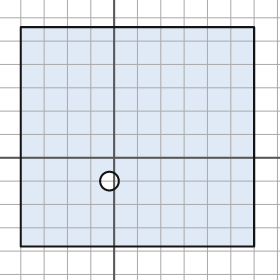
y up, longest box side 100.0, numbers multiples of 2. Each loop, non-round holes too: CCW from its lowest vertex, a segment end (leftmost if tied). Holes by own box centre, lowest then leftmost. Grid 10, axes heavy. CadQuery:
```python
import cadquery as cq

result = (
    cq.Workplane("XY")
    .moveTo(-40.0, -38.0)
    .lineTo(60.0, -38.0)
    .lineTo(60.0, 56.0)
    .lineTo(-40.0, 56.0)
    .close()
    .moveTo(-2.0, -10.0)
    .circle(4.0)
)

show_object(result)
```